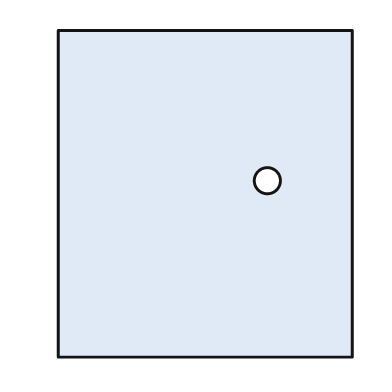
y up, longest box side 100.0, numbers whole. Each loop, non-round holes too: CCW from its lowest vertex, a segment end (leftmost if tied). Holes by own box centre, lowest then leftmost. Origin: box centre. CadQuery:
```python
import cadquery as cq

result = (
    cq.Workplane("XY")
    .moveTo(-45.0, -50.0)
    .lineTo(45.0, -50.0)
    .lineTo(45.0, 50.0)
    .lineTo(-45.0, 50.0)
    .close()
    .moveTo(19.0, 4.0)
    .circle(4.0)
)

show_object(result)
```